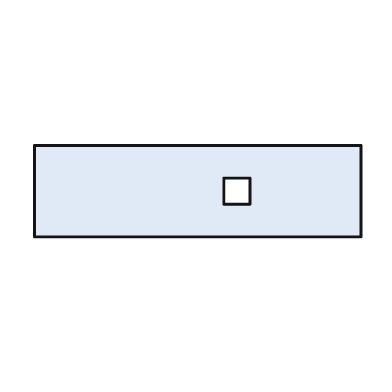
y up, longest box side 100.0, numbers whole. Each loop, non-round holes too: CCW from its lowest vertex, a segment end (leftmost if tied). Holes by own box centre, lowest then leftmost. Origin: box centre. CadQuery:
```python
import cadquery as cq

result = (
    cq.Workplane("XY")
    .moveTo(-50.0, -14.0)
    .lineTo(50.0, -14.0)
    .lineTo(50.0, 14.0)
    .lineTo(-50.0, 14.0)
    .close()
    .moveTo(8.0, -4.0)
    .lineTo(16.0, -4.0)
    .lineTo(16.0, 4.0)
    .lineTo(8.0, 4.0)
    .close()
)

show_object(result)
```